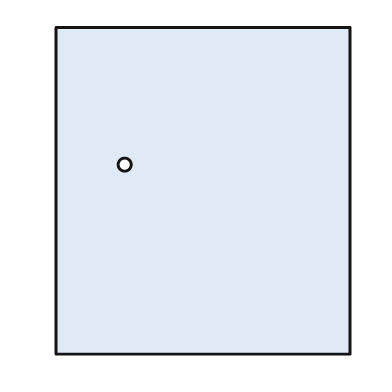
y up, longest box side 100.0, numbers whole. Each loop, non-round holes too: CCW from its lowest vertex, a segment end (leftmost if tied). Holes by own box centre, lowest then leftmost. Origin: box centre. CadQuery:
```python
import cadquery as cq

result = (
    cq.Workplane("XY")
    .moveTo(-45.0, -50.0)
    .lineTo(45.0, -50.0)
    .lineTo(45.0, 50.0)
    .lineTo(-45.0, 50.0)
    .close()
    .moveTo(-24.0, 8.0)
    .circle(2.0)
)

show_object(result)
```